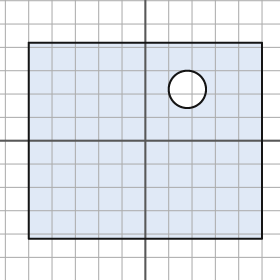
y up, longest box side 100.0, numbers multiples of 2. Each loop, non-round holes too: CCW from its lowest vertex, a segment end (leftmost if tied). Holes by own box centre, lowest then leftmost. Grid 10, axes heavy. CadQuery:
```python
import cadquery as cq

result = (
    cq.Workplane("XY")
    .moveTo(-50.0, -42.0)
    .lineTo(50.0, -42.0)
    .lineTo(50.0, 42.0)
    .lineTo(-50.0, 42.0)
    .close()
    .moveTo(18.0, 22.0)
    .circle(8.0)
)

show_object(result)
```